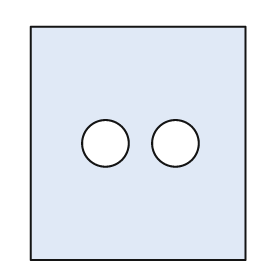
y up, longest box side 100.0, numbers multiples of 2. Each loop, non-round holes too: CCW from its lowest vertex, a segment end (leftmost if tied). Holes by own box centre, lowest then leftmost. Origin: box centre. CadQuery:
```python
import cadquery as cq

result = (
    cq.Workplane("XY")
    .moveTo(-46.0, -50.0)
    .lineTo(46.0, -50.0)
    .lineTo(46.0, 50.0)
    .lineTo(-46.0, 50.0)
    .close()
    .moveTo(-14.0, 0.0)
    .circle(10.0)
    .moveTo(16.0, 0.0)
    .circle(10.0)
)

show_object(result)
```